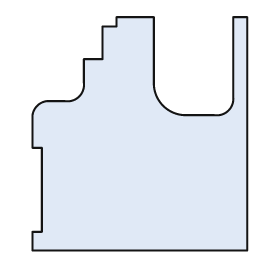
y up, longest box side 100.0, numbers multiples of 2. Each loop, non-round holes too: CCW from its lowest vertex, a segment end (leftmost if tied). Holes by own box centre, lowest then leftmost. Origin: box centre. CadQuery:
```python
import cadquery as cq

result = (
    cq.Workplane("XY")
    .moveTo(-46.0, -50.0)
    .lineTo(46.0, -50.0)
    .lineTo(46.0, 50.0)
    .lineTo(40.0, 50.0)
    .lineTo(40.0, 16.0)
    .threePointArc((38.0, 10.0), (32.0, 8.0))
    .lineTo(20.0, 8.0)
    .threePointArc((10.0, 12.0), (6.0, 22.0))
    .lineTo(6.0, 50.0)
    .lineTo(-10.0, 50.0)
    .lineTo(-10.0, 46.0)
    .lineTo(-16.0, 46.0)
    .lineTo(-16.0, 32.0)
    .lineTo(-24.0, 32.0)
    .lineTo(-24.0, 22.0)
    .threePointArc((-26.0, 16.0), (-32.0, 14.0))
    .lineTo(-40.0, 14.0)
    .threePointArc((-44.0, 12.0), (-46.0, 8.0))
    .lineTo(-46.0, -6.0)
    .lineTo(-42.0, -6.0)
    .lineTo(-42.0, -42.0)
    .lineTo(-46.0, -42.0)
    .close()
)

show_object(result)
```